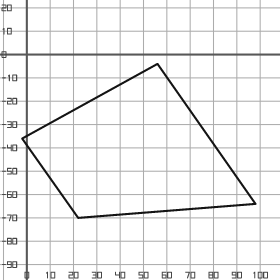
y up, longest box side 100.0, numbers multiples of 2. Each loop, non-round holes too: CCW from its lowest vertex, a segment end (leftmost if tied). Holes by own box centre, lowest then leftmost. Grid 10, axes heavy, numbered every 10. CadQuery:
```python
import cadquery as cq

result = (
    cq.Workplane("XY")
    .moveTo(22.0, -70.0)
    .lineTo(98.0, -64.0)
    .lineTo(56.0, -4.0)
    .lineTo(-2.0, -36.0)
    .close()
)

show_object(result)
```